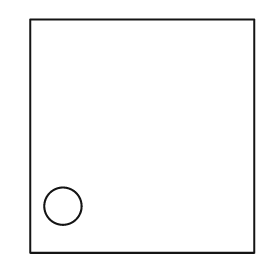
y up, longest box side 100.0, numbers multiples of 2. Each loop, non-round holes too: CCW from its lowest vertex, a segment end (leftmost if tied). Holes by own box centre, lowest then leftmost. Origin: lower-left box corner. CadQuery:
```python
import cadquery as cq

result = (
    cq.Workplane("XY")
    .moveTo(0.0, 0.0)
    .lineTo(96.0, 0.0)
    .lineTo(96.0, 100.0)
    .lineTo(0.0, 100.0)
    .close()
    .moveTo(14.0, 20.0)
    .circle(8.0)
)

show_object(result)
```